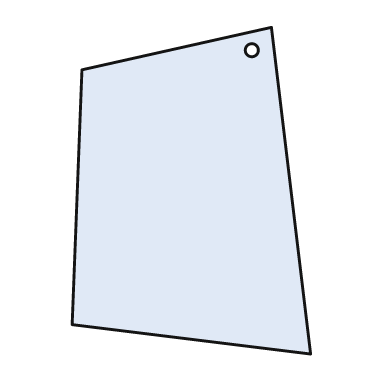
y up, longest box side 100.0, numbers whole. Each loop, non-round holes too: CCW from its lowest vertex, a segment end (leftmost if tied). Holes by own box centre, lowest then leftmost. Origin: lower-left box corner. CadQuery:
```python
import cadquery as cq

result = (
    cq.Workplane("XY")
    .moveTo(73.0, 0.0)
    .lineTo(61.0, 100.0)
    .lineTo(3.0, 87.0)
    .lineTo(0.0, 9.0)
    .close()
    .moveTo(55.0, 93.0)
    .circle(2.0)
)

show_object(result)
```